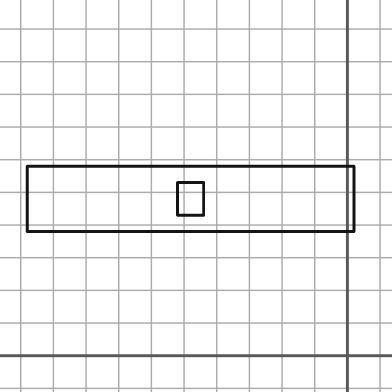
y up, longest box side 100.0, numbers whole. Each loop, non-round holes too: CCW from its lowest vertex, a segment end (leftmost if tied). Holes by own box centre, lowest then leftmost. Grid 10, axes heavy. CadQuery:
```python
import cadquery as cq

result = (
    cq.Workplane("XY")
    .moveTo(-98.0, 38.0)
    .lineTo(2.0, 38.0)
    .lineTo(2.0, 58.0)
    .lineTo(-98.0, 58.0)
    .close()
    .moveTo(-52.0, 43.0)
    .lineTo(-44.0, 43.0)
    .lineTo(-44.0, 53.0)
    .lineTo(-52.0, 53.0)
    .close()
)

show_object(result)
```